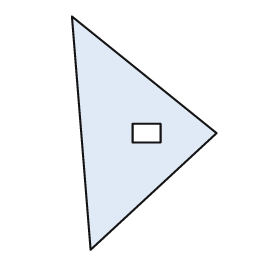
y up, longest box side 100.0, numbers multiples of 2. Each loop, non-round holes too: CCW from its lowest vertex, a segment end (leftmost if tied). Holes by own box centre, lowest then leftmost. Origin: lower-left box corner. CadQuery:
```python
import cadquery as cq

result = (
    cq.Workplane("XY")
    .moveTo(8.0, 0.0)
    .lineTo(62.0, 50.0)
    .lineTo(0.0, 100.0)
    .close()
    .moveTo(26.0, 46.0)
    .lineTo(38.0, 46.0)
    .lineTo(38.0, 54.0)
    .lineTo(26.0, 54.0)
    .close()
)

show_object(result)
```